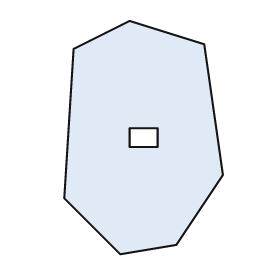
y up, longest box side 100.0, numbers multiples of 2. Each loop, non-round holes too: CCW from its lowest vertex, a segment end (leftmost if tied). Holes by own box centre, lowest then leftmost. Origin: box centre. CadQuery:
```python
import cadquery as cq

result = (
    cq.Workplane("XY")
    .moveTo(-10.0, -50.0)
    .lineTo(14.0, -46.0)
    .lineTo(34.0, -16.0)
    .lineTo(26.0, 40.0)
    .lineTo(-6.0, 50.0)
    .lineTo(-30.0, 38.0)
    .lineTo(-34.0, -26.0)
    .close()
    .moveTo(-6.0, -4.0)
    .lineTo(6.0, -4.0)
    .lineTo(6.0, 4.0)
    .lineTo(-6.0, 4.0)
    .close()
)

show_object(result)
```